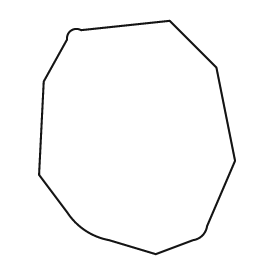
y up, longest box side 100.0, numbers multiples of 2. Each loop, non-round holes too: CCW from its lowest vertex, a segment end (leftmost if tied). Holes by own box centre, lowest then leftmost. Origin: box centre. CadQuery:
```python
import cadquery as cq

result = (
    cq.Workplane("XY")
    .moveTo(8.0, -50.0)
    .lineTo(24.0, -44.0)
    .threePointArc((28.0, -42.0), (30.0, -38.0))
    .lineTo(42.0, -10.0)
    .lineTo(34.0, 30.0)
    .lineTo(14.0, 50.0)
    .lineTo(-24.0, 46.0)
    .threePointArc((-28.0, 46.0), (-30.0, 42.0))
    .lineTo(-40.0, 24.0)
    .lineTo(-42.0, -16.0)
    .lineTo(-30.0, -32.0)
    .threePointArc((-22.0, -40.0), (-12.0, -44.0))
    .close()
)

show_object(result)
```